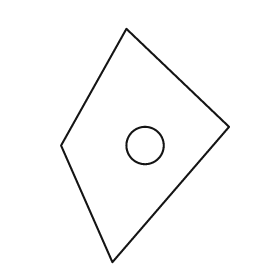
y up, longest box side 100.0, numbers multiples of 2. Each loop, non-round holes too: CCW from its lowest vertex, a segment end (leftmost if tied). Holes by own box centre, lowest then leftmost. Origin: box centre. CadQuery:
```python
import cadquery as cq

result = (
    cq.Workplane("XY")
    .moveTo(-14.0, -50.0)
    .lineTo(36.0, 8.0)
    .lineTo(-8.0, 50.0)
    .lineTo(-36.0, 0.0)
    .close()
    .moveTo(0.0, 0.0)
    .circle(8.0)
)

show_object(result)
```